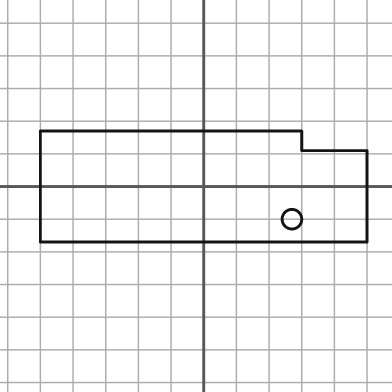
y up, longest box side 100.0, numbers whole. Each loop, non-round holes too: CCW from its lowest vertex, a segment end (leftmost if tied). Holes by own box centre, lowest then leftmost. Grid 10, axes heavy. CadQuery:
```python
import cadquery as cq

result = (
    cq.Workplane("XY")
    .moveTo(-50.0, -17.0)
    .lineTo(50.0, -17.0)
    .lineTo(50.0, 11.0)
    .lineTo(30.0, 11.0)
    .lineTo(30.0, 17.0)
    .lineTo(-50.0, 17.0)
    .close()
    .moveTo(27.0, -10.0)
    .circle(3.0)
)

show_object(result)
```